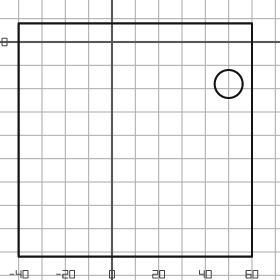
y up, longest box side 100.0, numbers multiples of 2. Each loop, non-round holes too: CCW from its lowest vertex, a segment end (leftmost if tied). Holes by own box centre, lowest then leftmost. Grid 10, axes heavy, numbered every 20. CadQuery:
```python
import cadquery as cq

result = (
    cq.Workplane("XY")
    .moveTo(-40.0, -92.0)
    .lineTo(60.0, -92.0)
    .lineTo(60.0, 8.0)
    .lineTo(-40.0, 8.0)
    .close()
    .moveTo(50.0, -18.0)
    .circle(6.0)
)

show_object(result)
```